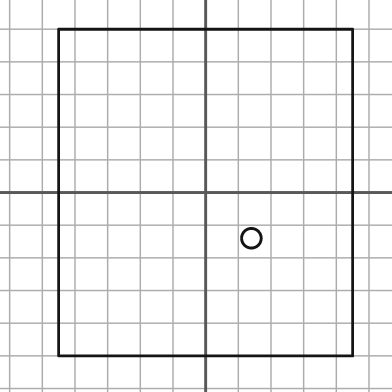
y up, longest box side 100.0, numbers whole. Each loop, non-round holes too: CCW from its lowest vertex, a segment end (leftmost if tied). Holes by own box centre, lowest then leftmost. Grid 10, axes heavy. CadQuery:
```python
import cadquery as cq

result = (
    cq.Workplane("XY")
    .moveTo(-45.0, -50.0)
    .lineTo(45.0, -50.0)
    .lineTo(45.0, 50.0)
    .lineTo(-45.0, 50.0)
    .close()
    .moveTo(14.0, -14.0)
    .circle(3.0)
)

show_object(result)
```